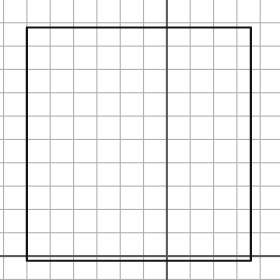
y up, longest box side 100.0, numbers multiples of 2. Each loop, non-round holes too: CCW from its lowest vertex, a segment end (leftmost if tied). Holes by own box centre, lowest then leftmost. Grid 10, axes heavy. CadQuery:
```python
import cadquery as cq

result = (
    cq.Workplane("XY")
    .moveTo(-60.0, -2.0)
    .lineTo(36.0, -2.0)
    .lineTo(36.0, 98.0)
    .lineTo(-60.0, 98.0)
    .close()
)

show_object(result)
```